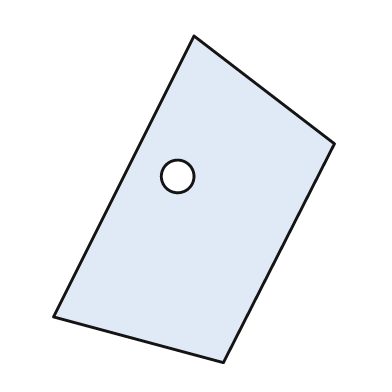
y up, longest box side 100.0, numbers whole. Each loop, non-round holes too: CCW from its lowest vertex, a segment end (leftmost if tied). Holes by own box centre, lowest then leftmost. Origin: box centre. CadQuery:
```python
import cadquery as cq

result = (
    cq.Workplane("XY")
    .moveTo(9.0, -50.0)
    .lineTo(43.0, 17.0)
    .lineTo(0.0, 50.0)
    .lineTo(-43.0, -36.0)
    .close()
    .moveTo(-5.0, 7.0)
    .circle(5.0)
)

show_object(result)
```